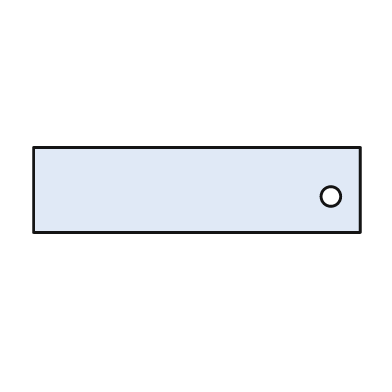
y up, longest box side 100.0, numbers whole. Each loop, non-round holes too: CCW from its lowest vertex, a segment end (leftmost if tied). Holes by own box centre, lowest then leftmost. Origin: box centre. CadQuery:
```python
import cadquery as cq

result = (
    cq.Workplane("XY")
    .moveTo(-50.0, -13.0)
    .lineTo(50.0, -13.0)
    .lineTo(50.0, 13.0)
    .lineTo(-50.0, 13.0)
    .close()
    .moveTo(41.0, -2.0)
    .circle(3.0)
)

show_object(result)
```